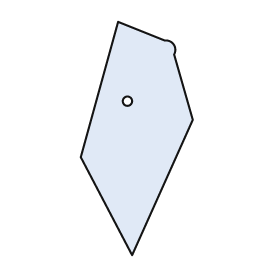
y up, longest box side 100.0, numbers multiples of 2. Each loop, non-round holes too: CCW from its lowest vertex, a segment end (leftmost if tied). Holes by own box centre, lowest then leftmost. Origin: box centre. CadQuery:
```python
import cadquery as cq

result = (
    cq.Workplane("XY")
    .moveTo(-2.0, -50.0)
    .lineTo(24.0, 8.0)
    .lineTo(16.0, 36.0)
    .threePointArc((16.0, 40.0), (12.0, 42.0))
    .lineTo(-8.0, 50.0)
    .lineTo(-24.0, -8.0)
    .close()
    .moveTo(-4.0, 16.0)
    .circle(2.0)
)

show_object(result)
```